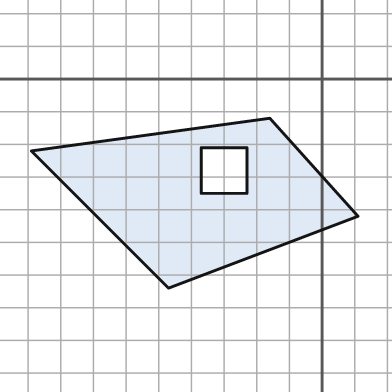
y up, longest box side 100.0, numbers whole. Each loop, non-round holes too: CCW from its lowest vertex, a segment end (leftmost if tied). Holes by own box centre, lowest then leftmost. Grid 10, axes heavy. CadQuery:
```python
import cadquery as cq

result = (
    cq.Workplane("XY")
    .moveTo(-47.0, -64.0)
    .lineTo(11.0, -42.0)
    .lineTo(-16.0, -12.0)
    .lineTo(-89.0, -22.0)
    .close()
    .moveTo(-37.0, -35.0)
    .lineTo(-23.0, -35.0)
    .lineTo(-23.0, -21.0)
    .lineTo(-37.0, -21.0)
    .close()
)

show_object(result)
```